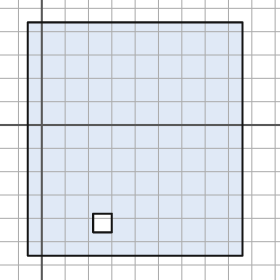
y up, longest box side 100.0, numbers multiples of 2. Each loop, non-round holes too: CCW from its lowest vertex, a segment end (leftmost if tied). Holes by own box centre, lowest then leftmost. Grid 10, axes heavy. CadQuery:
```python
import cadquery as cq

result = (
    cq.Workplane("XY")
    .moveTo(-6.0, -56.0)
    .lineTo(86.0, -56.0)
    .lineTo(86.0, 44.0)
    .lineTo(-6.0, 44.0)
    .close()
    .moveTo(22.0, -46.0)
    .lineTo(30.0, -46.0)
    .lineTo(30.0, -38.0)
    .lineTo(22.0, -38.0)
    .close()
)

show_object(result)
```